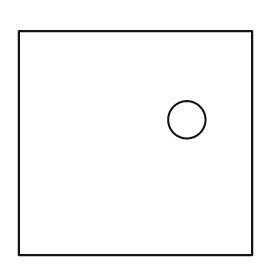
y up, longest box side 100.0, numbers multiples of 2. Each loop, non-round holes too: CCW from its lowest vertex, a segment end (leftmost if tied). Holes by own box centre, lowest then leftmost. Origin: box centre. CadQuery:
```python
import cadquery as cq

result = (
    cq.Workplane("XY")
    .moveTo(-50.0, -48.0)
    .lineTo(50.0, -48.0)
    .lineTo(50.0, 48.0)
    .lineTo(-50.0, 48.0)
    .close()
    .moveTo(22.0, 10.0)
    .circle(8.0)
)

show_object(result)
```